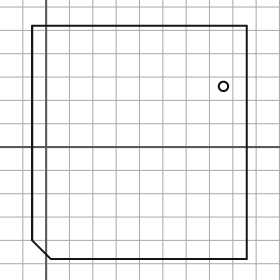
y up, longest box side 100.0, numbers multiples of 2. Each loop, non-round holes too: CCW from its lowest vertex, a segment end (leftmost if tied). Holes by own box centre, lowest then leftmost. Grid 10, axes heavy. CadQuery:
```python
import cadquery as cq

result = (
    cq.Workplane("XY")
    .moveTo(2.0, -48.0)
    .lineTo(86.0, -48.0)
    .lineTo(86.0, 52.0)
    .lineTo(-6.0, 52.0)
    .lineTo(-6.0, -40.0)
    .close()
    .moveTo(76.0, 26.0)
    .circle(2.0)
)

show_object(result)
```